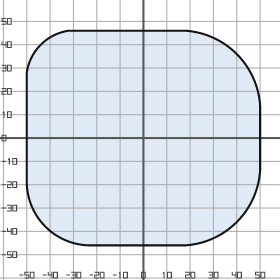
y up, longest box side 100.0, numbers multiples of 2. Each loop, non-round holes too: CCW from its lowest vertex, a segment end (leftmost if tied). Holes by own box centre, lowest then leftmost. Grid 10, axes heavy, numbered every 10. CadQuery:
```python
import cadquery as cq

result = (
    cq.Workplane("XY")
    .moveTo(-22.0, -46.0)
    .lineTo(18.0, -46.0)
    .threePointArc((40.0, -36.0), (50.0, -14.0))
    .lineTo(50.0, 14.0)
    .threePointArc((40.0, 36.0), (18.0, 46.0))
    .lineTo(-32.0, 46.0)
    .threePointArc((-44.0, 40.0), (-50.0, 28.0))
    .lineTo(-50.0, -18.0)
    .threePointArc((-42.0, -38.0), (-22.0, -46.0))
    .close()
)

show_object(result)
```